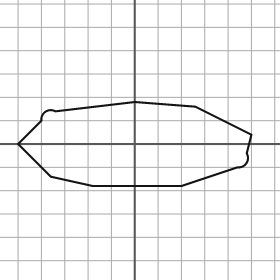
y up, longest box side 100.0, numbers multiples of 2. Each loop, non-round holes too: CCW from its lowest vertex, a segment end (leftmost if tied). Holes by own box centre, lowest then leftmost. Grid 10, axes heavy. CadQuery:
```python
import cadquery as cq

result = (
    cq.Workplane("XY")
    .moveTo(-18.0, -18.0)
    .lineTo(20.0, -18.0)
    .lineTo(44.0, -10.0)
    .threePointArc((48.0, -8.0), (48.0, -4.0))
    .lineTo(50.0, 4.0)
    .lineTo(26.0, 16.0)
    .lineTo(0.0, 18.0)
    .lineTo(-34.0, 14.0)
    .threePointArc((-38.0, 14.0), (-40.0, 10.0))
    .lineTo(-50.0, 0.0)
    .lineTo(-36.0, -14.0)
    .close()
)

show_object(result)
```